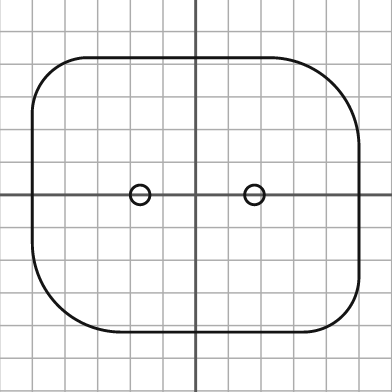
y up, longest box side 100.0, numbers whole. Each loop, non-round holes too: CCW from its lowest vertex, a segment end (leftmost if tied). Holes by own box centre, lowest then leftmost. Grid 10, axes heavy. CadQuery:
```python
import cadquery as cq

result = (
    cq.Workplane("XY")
    .moveTo(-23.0, -42.0)
    .lineTo(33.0, -42.0)
    .threePointArc((45.0, -37.0), (50.0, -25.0))
    .lineTo(50.0, 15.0)
    .threePointArc((42.0, 34.0), (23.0, 42.0))
    .lineTo(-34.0, 42.0)
    .threePointArc((-45.0, 37.0), (-50.0, 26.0))
    .lineTo(-50.0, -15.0)
    .threePointArc((-42.0, -34.0), (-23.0, -42.0))
    .close()
    .moveTo(-17.0, 0.0)
    .circle(3.0)
    .moveTo(18.0, 0.0)
    .circle(3.0)
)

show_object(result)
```